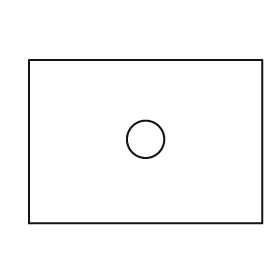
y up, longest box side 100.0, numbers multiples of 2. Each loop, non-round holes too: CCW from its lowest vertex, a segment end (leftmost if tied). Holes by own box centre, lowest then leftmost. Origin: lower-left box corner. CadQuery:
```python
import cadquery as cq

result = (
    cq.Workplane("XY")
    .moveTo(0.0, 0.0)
    .lineTo(100.0, 0.0)
    .lineTo(100.0, 70.0)
    .lineTo(0.0, 70.0)
    .close()
    .moveTo(50.0, 36.0)
    .circle(8.0)
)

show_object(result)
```